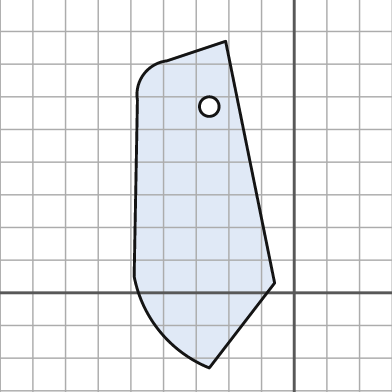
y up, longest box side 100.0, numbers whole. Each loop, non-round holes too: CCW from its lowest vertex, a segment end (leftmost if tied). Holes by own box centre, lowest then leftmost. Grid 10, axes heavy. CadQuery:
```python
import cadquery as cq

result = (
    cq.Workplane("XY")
    .moveTo(-26.0, -23.0)
    .lineTo(-6.0, 3.0)
    .lineTo(-21.0, 77.0)
    .lineTo(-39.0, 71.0)
    .threePointArc((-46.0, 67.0), (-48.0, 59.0))
    .lineTo(-49.0, 5.0)
    .threePointArc((-41.0, -12.0), (-26.0, -23.0))
    .close()
    .moveTo(-26.0, 57.0)
    .circle(3.0)
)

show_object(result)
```